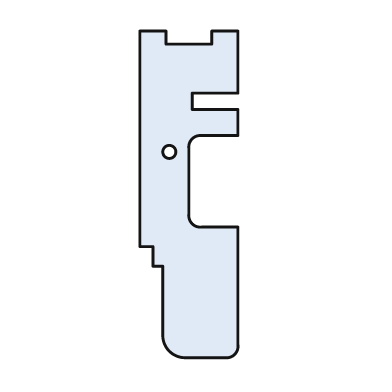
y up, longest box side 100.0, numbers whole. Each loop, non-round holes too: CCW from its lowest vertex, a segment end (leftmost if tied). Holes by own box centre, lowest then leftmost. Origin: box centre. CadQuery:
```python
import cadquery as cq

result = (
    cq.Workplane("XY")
    .moveTo(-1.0, -50.0)
    .lineTo(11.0, -50.0)
    .threePointArc((14.0, -49.0), (15.0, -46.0))
    .lineTo(15.0, -10.0)
    .lineTo(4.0, -10.0)
    .threePointArc((1.0, -9.0), (0.0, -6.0))
    .lineTo(0.0, 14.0)
    .threePointArc((1.0, 17.0), (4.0, 18.0))
    .lineTo(15.0, 18.0)
    .lineTo(15.0, 26.0)
    .lineTo(1.0, 26.0)
    .lineTo(1.0, 31.0)
    .lineTo(15.0, 31.0)
    .lineTo(15.0, 50.0)
    .lineTo(7.0, 50.0)
    .lineTo(7.0, 46.0)
    .lineTo(-7.0, 46.0)
    .lineTo(-7.0, 50.0)
    .lineTo(-15.0, 50.0)
    .lineTo(-15.0, -16.0)
    .lineTo(-11.0, -16.0)
    .lineTo(-11.0, -22.0)
    .lineTo(-8.0, -22.0)
    .lineTo(-8.0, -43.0)
    .threePointArc((-6.0, -48.0), (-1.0, -50.0))
    .close()
    .moveTo(-6.0, 13.0)
    .circle(2.0)
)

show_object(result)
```